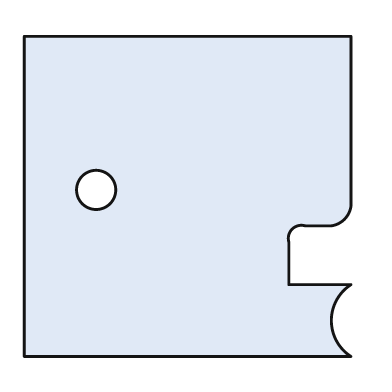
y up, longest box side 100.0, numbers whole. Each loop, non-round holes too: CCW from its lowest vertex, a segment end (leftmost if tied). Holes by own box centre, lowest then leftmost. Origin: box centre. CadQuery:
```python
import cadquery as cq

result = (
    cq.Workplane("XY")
    .moveTo(-50.0, -49.0)
    .lineTo(50.0, -49.0)
    .threePointArc((44.0, -38.0), (50.0, -27.0))
    .lineTo(31.0, -27.0)
    .lineTo(31.0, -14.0)
    .threePointArc((32.0, -10.0), (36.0, -9.0))
    .lineTo(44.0, -9.0)
    .threePointArc((48.0, -7.0), (50.0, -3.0))
    .lineTo(50.0, 49.0)
    .lineTo(-50.0, 49.0)
    .close()
    .moveTo(-28.0, 2.0)
    .circle(6.0)
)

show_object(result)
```